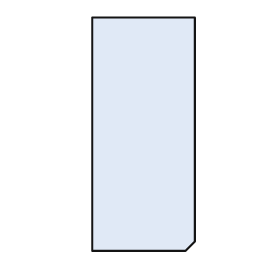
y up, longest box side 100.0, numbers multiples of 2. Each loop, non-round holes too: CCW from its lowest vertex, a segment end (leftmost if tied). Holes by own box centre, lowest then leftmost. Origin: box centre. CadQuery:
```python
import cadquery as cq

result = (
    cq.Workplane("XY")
    .moveTo(-22.0, -50.0)
    .lineTo(18.0, -50.0)
    .lineTo(22.0, -46.0)
    .lineTo(22.0, 50.0)
    .lineTo(-22.0, 50.0)
    .close()
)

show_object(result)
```